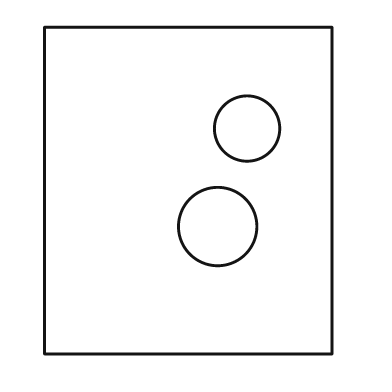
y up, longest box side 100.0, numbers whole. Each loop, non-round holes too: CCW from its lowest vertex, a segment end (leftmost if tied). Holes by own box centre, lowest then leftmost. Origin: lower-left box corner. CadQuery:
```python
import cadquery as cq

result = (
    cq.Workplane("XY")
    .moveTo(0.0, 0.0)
    .lineTo(88.0, 0.0)
    .lineTo(88.0, 100.0)
    .lineTo(0.0, 100.0)
    .close()
    .moveTo(53.0, 39.0)
    .circle(12.0)
    .moveTo(62.0, 69.0)
    .circle(10.0)
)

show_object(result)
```